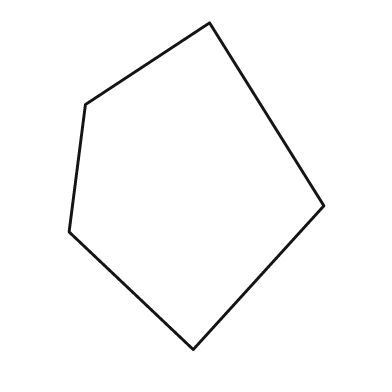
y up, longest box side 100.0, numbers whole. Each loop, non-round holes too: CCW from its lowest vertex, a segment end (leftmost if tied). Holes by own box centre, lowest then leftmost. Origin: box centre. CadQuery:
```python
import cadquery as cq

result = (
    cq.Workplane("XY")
    .moveTo(-1.0, -50.0)
    .lineTo(39.0, -6.0)
    .lineTo(4.0, 50.0)
    .lineTo(-34.0, 25.0)
    .lineTo(-39.0, -14.0)
    .close()
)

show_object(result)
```